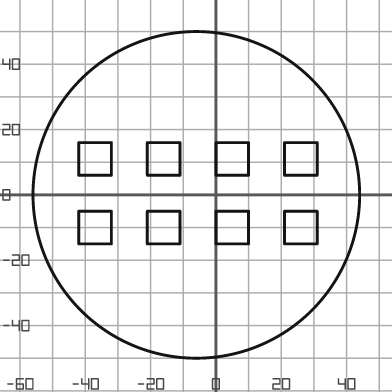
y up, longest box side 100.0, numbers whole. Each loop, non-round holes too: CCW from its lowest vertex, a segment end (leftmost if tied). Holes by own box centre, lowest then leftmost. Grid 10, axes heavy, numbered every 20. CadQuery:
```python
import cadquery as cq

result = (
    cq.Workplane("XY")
    .moveTo(-6.0, 0.0)
    .circle(50.0)
    .moveTo(-42.0, -15.0)
    .lineTo(-32.0, -15.0)
    .lineTo(-32.0, -5.0)
    .lineTo(-42.0, -5.0)
    .close()
    .moveTo(-21.0, -15.0)
    .lineTo(-11.0, -15.0)
    .lineTo(-11.0, -5.0)
    .lineTo(-21.0, -5.0)
    .close()
    .moveTo(0.0, -15.0)
    .lineTo(10.0, -15.0)
    .lineTo(10.0, -5.0)
    .lineTo(0.0, -5.0)
    .close()
    .moveTo(21.0, -15.0)
    .lineTo(31.0, -15.0)
    .lineTo(31.0, -5.0)
    .lineTo(21.0, -5.0)
    .close()
    .moveTo(-42.0, 6.0)
    .lineTo(-32.0, 6.0)
    .lineTo(-32.0, 16.0)
    .lineTo(-42.0, 16.0)
    .close()
    .moveTo(-21.0, 6.0)
    .lineTo(-11.0, 6.0)
    .lineTo(-11.0, 16.0)
    .lineTo(-21.0, 16.0)
    .close()
    .moveTo(0.0, 6.0)
    .lineTo(10.0, 6.0)
    .lineTo(10.0, 16.0)
    .lineTo(0.0, 16.0)
    .close()
    .moveTo(21.0, 6.0)
    .lineTo(31.0, 6.0)
    .lineTo(31.0, 16.0)
    .lineTo(21.0, 16.0)
    .close()
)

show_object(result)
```